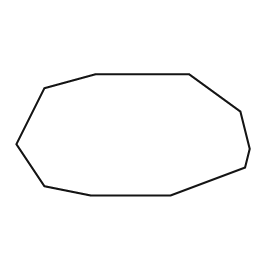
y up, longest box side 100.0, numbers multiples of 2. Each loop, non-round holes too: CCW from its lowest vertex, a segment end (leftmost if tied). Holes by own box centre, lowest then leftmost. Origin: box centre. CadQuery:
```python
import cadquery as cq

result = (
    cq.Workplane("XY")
    .moveTo(-18.0, -26.0)
    .lineTo(16.0, -26.0)
    .lineTo(48.0, -14.0)
    .lineTo(50.0, -6.0)
    .lineTo(46.0, 10.0)
    .lineTo(24.0, 26.0)
    .lineTo(-16.0, 26.0)
    .lineTo(-38.0, 20.0)
    .lineTo(-50.0, -4.0)
    .lineTo(-38.0, -22.0)
    .close()
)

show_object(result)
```